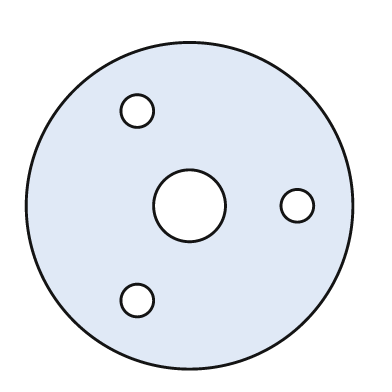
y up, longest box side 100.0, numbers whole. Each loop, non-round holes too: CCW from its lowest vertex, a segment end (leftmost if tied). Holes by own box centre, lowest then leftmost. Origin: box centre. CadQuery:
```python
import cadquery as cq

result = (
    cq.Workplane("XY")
    .moveTo(0.0, 0.0)
    .circle(50.0)
    .moveTo(-16.0, -29.0)
    .circle(5.0)
    .moveTo(0.0, 0.0)
    .circle(11.0)
    .moveTo(33.0, 0.0)
    .circle(5.0)
    .moveTo(-16.0, 29.0)
    .circle(5.0)
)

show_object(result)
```